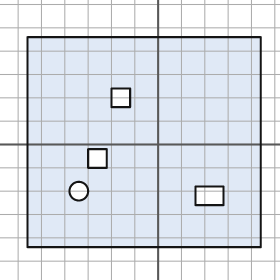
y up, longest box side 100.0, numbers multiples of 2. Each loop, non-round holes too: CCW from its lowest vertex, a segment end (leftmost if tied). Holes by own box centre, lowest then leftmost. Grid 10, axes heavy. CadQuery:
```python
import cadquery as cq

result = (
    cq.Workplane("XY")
    .moveTo(-56.0, -44.0)
    .lineTo(44.0, -44.0)
    .lineTo(44.0, 46.0)
    .lineTo(-56.0, 46.0)
    .close()
    .moveTo(16.0, -26.0)
    .lineTo(28.0, -26.0)
    .lineTo(28.0, -18.0)
    .lineTo(16.0, -18.0)
    .close()
    .moveTo(-34.0, -20.0)
    .circle(4.0)
    .moveTo(-30.0, -10.0)
    .lineTo(-22.0, -10.0)
    .lineTo(-22.0, -2.0)
    .lineTo(-30.0, -2.0)
    .close()
    .moveTo(-20.0, 16.0)
    .lineTo(-12.0, 16.0)
    .lineTo(-12.0, 24.0)
    .lineTo(-20.0, 24.0)
    .close()
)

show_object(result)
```